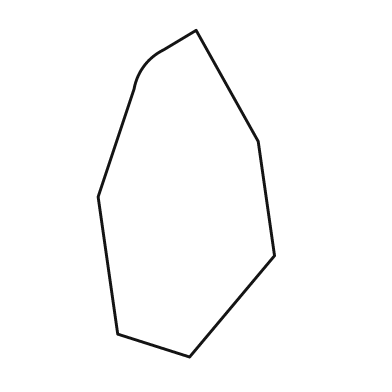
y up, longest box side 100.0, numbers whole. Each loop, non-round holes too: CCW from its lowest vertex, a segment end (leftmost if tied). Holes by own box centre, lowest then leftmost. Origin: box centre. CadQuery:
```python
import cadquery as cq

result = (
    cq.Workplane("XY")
    .moveTo(1.0, -50.0)
    .lineTo(27.0, -19.0)
    .lineTo(22.0, 16.0)
    .lineTo(3.0, 50.0)
    .lineTo(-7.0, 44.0)
    .threePointArc((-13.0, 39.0), (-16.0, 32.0))
    .lineTo(-27.0, -1.0)
    .lineTo(-21.0, -43.0)
    .close()
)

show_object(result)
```